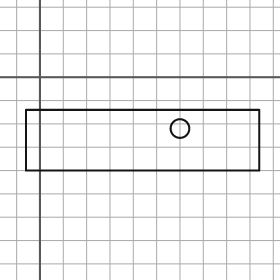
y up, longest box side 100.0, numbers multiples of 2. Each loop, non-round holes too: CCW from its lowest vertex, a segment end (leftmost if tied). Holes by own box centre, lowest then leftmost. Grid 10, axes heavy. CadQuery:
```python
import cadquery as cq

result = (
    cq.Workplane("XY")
    .moveTo(-6.0, -40.0)
    .lineTo(94.0, -40.0)
    .lineTo(94.0, -14.0)
    .lineTo(-6.0, -14.0)
    .close()
    .moveTo(60.0, -22.0)
    .circle(4.0)
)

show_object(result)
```